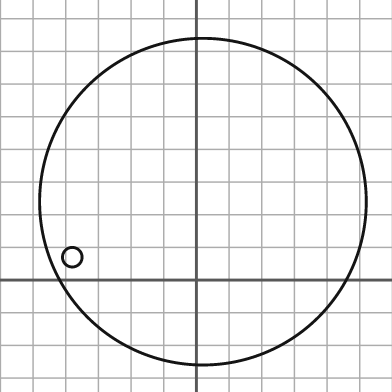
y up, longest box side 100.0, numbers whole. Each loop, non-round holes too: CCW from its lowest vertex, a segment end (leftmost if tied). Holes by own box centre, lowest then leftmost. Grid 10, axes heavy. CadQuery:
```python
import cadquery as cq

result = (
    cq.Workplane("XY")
    .moveTo(2.0, 24.0)
    .circle(50.0)
    .moveTo(-38.0, 7.0)
    .circle(3.0)
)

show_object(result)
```